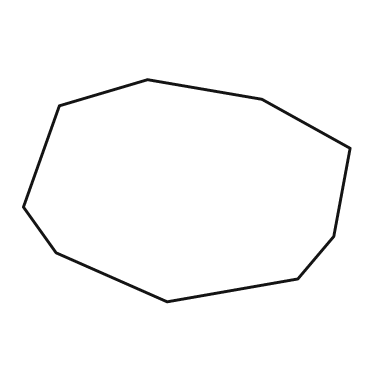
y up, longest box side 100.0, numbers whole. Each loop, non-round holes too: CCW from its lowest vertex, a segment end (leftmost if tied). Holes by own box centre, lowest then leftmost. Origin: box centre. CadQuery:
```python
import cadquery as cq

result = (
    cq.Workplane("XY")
    .moveTo(-6.0, -34.0)
    .lineTo(34.0, -27.0)
    .lineTo(45.0, -14.0)
    .lineTo(50.0, 13.0)
    .lineTo(23.0, 28.0)
    .lineTo(-12.0, 34.0)
    .lineTo(-39.0, 26.0)
    .lineTo(-50.0, -5.0)
    .lineTo(-40.0, -19.0)
    .close()
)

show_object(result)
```